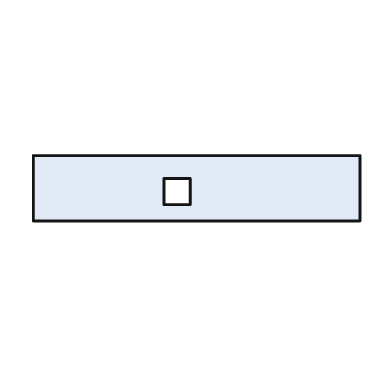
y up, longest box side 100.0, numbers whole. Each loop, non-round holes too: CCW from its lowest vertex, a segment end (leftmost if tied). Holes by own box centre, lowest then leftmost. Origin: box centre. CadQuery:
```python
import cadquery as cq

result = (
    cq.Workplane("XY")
    .moveTo(-50.0, -10.0)
    .lineTo(50.0, -10.0)
    .lineTo(50.0, 10.0)
    .lineTo(-50.0, 10.0)
    .close()
    .moveTo(-10.0, -5.0)
    .lineTo(-2.0, -5.0)
    .lineTo(-2.0, 3.0)
    .lineTo(-10.0, 3.0)
    .close()
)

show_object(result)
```